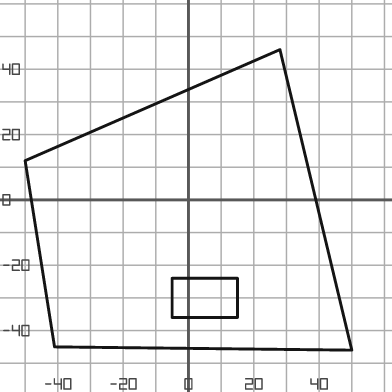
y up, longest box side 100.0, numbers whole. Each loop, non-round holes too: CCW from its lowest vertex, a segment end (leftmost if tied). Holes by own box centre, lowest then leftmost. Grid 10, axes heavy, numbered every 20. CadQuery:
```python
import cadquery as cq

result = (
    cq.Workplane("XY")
    .moveTo(50.0, -46.0)
    .lineTo(28.0, 46.0)
    .lineTo(-50.0, 12.0)
    .lineTo(-41.0, -45.0)
    .close()
    .moveTo(-5.0, -36.0)
    .lineTo(15.0, -36.0)
    .lineTo(15.0, -24.0)
    .lineTo(-5.0, -24.0)
    .close()
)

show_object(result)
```